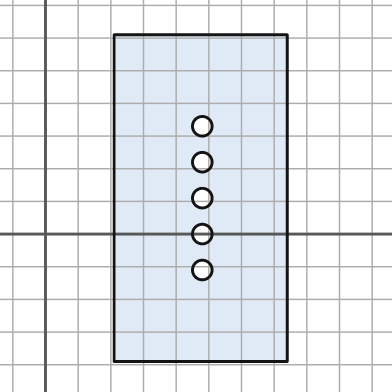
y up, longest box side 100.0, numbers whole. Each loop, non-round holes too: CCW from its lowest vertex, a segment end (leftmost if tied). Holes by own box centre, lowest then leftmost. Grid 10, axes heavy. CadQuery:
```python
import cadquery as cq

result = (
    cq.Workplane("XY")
    .moveTo(21.0, -39.0)
    .lineTo(74.0, -39.0)
    .lineTo(74.0, 61.0)
    .lineTo(21.0, 61.0)
    .close()
    .moveTo(48.0, -11.0)
    .circle(3.0)
    .moveTo(48.0, 0.0)
    .circle(3.0)
    .moveTo(48.0, 11.0)
    .circle(3.0)
    .moveTo(48.0, 22.0)
    .circle(3.0)
    .moveTo(48.0, 33.0)
    .circle(3.0)
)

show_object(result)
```